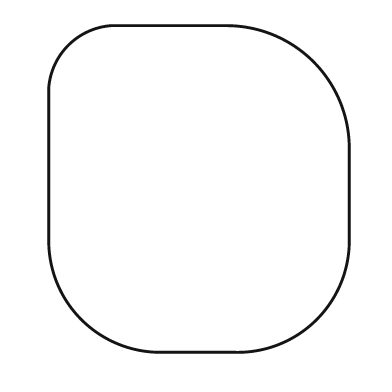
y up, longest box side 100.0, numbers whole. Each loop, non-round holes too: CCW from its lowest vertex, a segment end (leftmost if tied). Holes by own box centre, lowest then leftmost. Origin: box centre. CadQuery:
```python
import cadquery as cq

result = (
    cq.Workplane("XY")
    .moveTo(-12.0, -50.0)
    .lineTo(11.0, -50.0)
    .threePointArc((36.0, -40.0), (46.0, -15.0))
    .lineTo(46.0, 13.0)
    .threePointArc((35.0, 39.0), (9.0, 50.0))
    .lineTo(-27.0, 50.0)
    .threePointArc((-40.0, 44.0), (-46.0, 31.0))
    .lineTo(-46.0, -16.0)
    .threePointArc((-36.0, -40.0), (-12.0, -50.0))
    .close()
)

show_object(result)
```